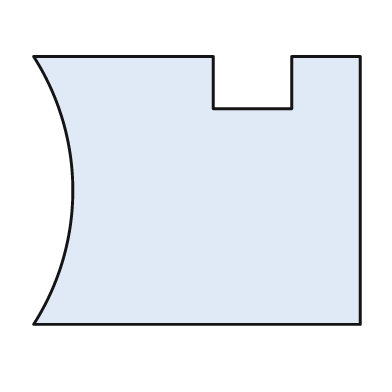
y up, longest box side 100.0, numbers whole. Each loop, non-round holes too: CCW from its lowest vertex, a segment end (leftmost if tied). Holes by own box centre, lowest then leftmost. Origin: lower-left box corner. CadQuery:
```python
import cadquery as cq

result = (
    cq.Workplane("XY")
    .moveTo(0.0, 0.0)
    .lineTo(100.0, 0.0)
    .lineTo(100.0, 82.0)
    .lineTo(79.0, 82.0)
    .lineTo(79.0, 66.0)
    .lineTo(55.0, 66.0)
    .lineTo(55.0, 82.0)
    .lineTo(0.0, 82.0)
    .threePointArc((12.0, 41.0), (0.0, 0.0))
    .close()
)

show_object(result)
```